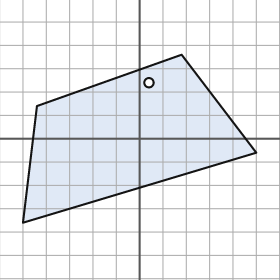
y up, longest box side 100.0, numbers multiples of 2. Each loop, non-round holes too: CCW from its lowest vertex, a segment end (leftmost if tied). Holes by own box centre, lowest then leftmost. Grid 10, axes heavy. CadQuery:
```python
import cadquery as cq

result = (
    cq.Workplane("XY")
    .moveTo(-50.0, -36.0)
    .lineTo(50.0, -6.0)
    .lineTo(18.0, 36.0)
    .lineTo(-44.0, 14.0)
    .close()
    .moveTo(4.0, 24.0)
    .circle(2.0)
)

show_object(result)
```